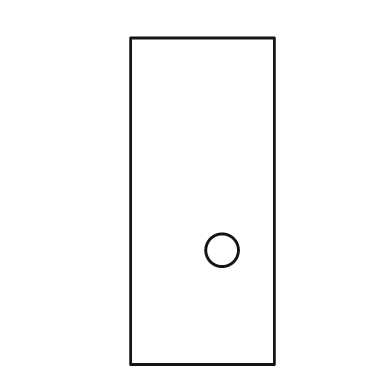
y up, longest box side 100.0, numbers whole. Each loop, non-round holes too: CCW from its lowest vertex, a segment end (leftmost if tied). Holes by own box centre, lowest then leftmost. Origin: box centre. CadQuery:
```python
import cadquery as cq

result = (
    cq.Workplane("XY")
    .moveTo(-22.0, -50.0)
    .lineTo(22.0, -50.0)
    .lineTo(22.0, 50.0)
    .lineTo(-22.0, 50.0)
    .close()
    .moveTo(6.0, -15.0)
    .circle(5.0)
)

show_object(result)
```